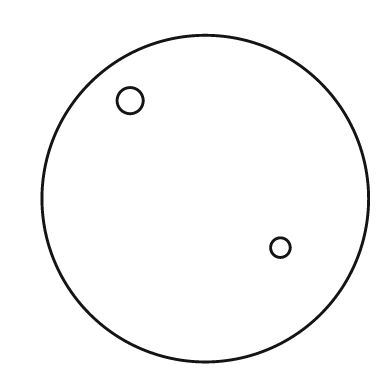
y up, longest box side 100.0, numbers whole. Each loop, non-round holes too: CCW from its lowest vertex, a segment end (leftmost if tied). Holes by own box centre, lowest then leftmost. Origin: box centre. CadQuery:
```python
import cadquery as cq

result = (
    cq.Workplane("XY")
    .moveTo(0.0, 0.0)
    .circle(50.0)
    .moveTo(23.0, -15.0)
    .circle(3.0)
    .moveTo(-23.0, 30.0)
    .circle(4.0)
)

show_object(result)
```